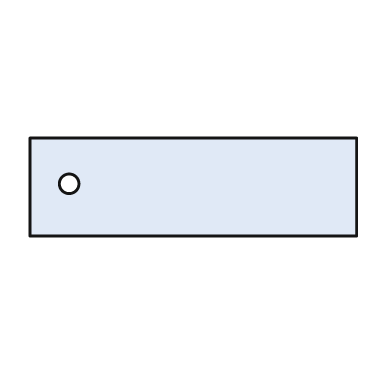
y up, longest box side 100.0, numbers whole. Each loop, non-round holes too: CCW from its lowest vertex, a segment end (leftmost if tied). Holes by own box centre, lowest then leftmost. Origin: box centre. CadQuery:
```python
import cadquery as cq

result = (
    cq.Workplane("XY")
    .moveTo(-50.0, -15.0)
    .lineTo(50.0, -15.0)
    .lineTo(50.0, 15.0)
    .lineTo(-50.0, 15.0)
    .close()
    .moveTo(-38.0, 1.0)
    .circle(3.0)
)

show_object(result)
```